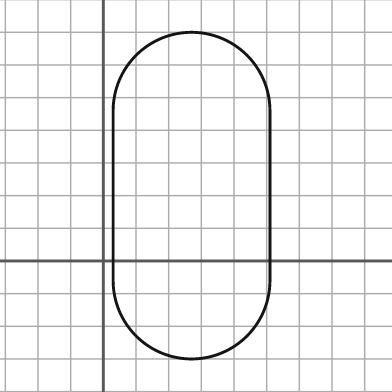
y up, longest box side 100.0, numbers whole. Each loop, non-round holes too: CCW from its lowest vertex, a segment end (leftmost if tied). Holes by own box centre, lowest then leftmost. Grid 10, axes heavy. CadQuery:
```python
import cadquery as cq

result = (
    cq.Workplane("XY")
    .moveTo(3.0, -6.0)
    .threePointArc((27.0, -30.0), (51.0, -6.0))
    .lineTo(51.0, 46.0)
    .threePointArc((27.0, 70.0), (3.0, 46.0))
    .close()
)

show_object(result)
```